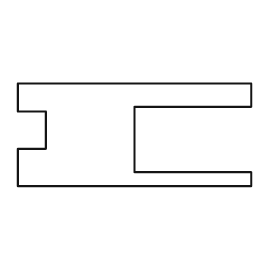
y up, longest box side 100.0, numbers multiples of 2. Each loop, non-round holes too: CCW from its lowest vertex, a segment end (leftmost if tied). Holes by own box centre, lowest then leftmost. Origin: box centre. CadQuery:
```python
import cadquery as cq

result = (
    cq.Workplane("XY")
    .moveTo(-50.0, -22.0)
    .lineTo(50.0, -22.0)
    .lineTo(50.0, -16.0)
    .lineTo(0.0, -16.0)
    .lineTo(0.0, 12.0)
    .lineTo(50.0, 12.0)
    .lineTo(50.0, 22.0)
    .lineTo(-50.0, 22.0)
    .lineTo(-50.0, 10.0)
    .lineTo(-38.0, 10.0)
    .lineTo(-38.0, -6.0)
    .lineTo(-50.0, -6.0)
    .close()
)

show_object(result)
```